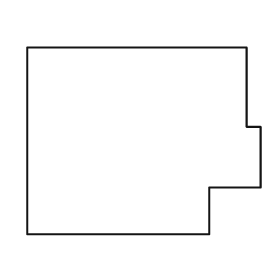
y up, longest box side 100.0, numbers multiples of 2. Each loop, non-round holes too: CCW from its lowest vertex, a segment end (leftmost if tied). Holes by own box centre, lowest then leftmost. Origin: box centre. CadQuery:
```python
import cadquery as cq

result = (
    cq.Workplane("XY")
    .moveTo(-50.0, -40.0)
    .lineTo(28.0, -40.0)
    .lineTo(28.0, -20.0)
    .lineTo(50.0, -20.0)
    .lineTo(50.0, 6.0)
    .lineTo(44.0, 6.0)
    .lineTo(44.0, 40.0)
    .lineTo(-50.0, 40.0)
    .close()
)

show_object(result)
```